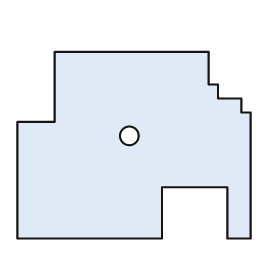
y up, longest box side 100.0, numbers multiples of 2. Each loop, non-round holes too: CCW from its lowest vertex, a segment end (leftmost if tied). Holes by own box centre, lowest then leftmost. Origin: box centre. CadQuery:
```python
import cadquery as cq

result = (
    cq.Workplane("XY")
    .moveTo(-50.0, -40.0)
    .lineTo(12.0, -40.0)
    .lineTo(12.0, -18.0)
    .lineTo(40.0, -18.0)
    .lineTo(40.0, -40.0)
    .lineTo(50.0, -40.0)
    .lineTo(50.0, 14.0)
    .lineTo(46.0, 14.0)
    .lineTo(46.0, 20.0)
    .lineTo(36.0, 20.0)
    .lineTo(36.0, 26.0)
    .lineTo(32.0, 26.0)
    .lineTo(32.0, 40.0)
    .lineTo(-34.0, 40.0)
    .lineTo(-34.0, 10.0)
    .lineTo(-50.0, 10.0)
    .close()
    .moveTo(-2.0, 4.0)
    .circle(4.0)
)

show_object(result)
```